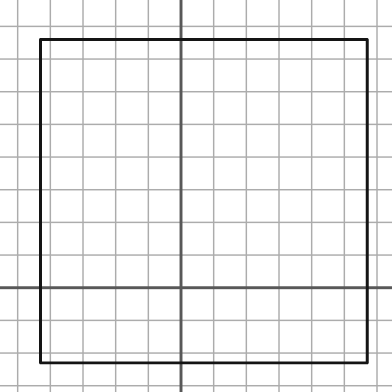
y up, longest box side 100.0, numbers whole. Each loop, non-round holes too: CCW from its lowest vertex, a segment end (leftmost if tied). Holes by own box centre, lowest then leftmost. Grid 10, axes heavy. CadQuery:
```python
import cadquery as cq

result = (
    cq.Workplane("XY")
    .moveTo(-43.0, -23.0)
    .lineTo(57.0, -23.0)
    .lineTo(57.0, 76.0)
    .lineTo(-43.0, 76.0)
    .close()
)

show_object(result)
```